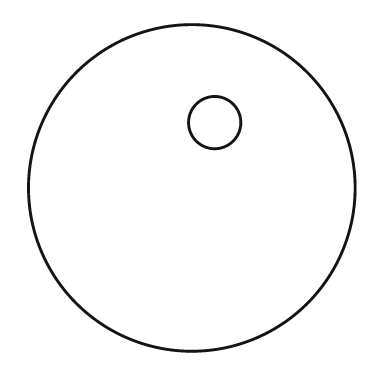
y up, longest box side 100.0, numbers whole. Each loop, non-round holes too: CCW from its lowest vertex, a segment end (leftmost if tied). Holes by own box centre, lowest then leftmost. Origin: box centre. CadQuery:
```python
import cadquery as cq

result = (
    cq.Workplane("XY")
    .moveTo(0.0, 0.0)
    .circle(50.0)
    .moveTo(7.0, 20.0)
    .circle(8.0)
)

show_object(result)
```